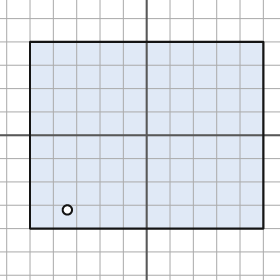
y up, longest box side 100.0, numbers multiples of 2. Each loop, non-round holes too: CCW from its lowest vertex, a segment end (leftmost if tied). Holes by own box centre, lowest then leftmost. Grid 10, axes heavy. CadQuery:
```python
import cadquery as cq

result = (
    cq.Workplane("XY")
    .moveTo(-50.0, -40.0)
    .lineTo(50.0, -40.0)
    .lineTo(50.0, 40.0)
    .lineTo(-50.0, 40.0)
    .close()
    .moveTo(-34.0, -32.0)
    .circle(2.0)
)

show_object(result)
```